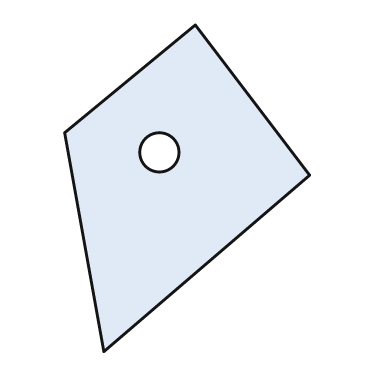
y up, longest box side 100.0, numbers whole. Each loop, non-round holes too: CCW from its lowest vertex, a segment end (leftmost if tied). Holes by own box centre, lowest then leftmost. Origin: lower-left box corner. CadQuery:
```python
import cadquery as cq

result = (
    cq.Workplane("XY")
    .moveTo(12.0, 0.0)
    .lineTo(75.0, 54.0)
    .lineTo(40.0, 100.0)
    .lineTo(0.0, 67.0)
    .close()
    .moveTo(29.0, 61.0)
    .circle(6.0)
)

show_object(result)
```